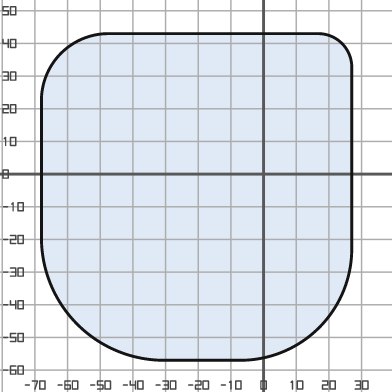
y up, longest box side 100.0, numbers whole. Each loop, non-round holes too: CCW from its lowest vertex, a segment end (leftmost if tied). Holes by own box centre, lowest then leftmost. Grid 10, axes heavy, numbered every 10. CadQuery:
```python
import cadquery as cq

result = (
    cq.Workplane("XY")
    .moveTo(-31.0, -57.0)
    .lineTo(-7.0, -57.0)
    .threePointArc((17.0, -47.0), (27.0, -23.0))
    .lineTo(27.0, 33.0)
    .threePointArc((24.0, 40.0), (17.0, 43.0))
    .lineTo(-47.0, 43.0)
    .threePointArc((-62.0, 37.0), (-68.0, 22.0))
    .lineTo(-68.0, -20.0)
    .threePointArc((-57.0, -46.0), (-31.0, -57.0))
    .close()
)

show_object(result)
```